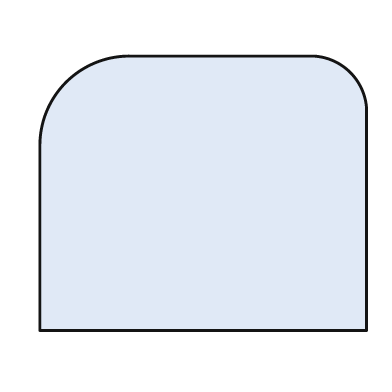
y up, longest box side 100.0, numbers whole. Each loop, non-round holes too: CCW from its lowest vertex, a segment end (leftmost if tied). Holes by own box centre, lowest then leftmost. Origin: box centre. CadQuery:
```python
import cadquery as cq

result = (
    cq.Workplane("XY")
    .moveTo(-50.0, -42.0)
    .lineTo(50.0, -42.0)
    .lineTo(50.0, 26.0)
    .threePointArc((45.0, 37.0), (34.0, 42.0))
    .lineTo(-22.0, 42.0)
    .threePointArc((-42.0, 34.0), (-50.0, 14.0))
    .close()
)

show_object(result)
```